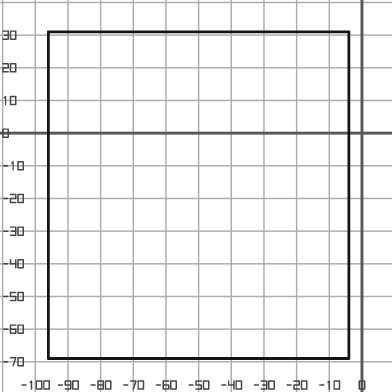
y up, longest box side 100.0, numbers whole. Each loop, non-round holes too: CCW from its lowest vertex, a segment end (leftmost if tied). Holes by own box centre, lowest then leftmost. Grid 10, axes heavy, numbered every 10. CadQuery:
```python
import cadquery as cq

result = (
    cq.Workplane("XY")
    .moveTo(-96.0, -69.0)
    .lineTo(-4.0, -69.0)
    .lineTo(-4.0, 31.0)
    .lineTo(-96.0, 31.0)
    .close()
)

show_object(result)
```